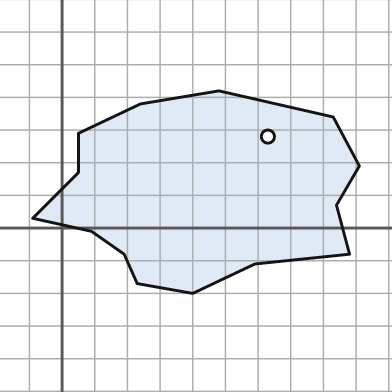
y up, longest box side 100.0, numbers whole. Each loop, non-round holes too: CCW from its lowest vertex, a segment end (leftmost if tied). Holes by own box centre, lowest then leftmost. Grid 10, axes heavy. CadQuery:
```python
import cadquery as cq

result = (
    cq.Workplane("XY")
    .moveTo(40.0, -20.0)
    .lineTo(59.0, -11.0)
    .lineTo(88.0, -8.0)
    .lineTo(84.0, 7.0)
    .lineTo(91.0, 19.0)
    .lineTo(83.0, 34.0)
    .lineTo(48.0, 42.0)
    .lineTo(24.0, 38.0)
    .lineTo(5.0, 29.0)
    .lineTo(5.0, 17.0)
    .lineTo(-9.0, 3.0)
    .lineTo(9.0, -1.0)
    .lineTo(19.0, -8.0)
    .lineTo(23.0, -17.0)
    .close()
    .moveTo(63.0, 28.0)
    .circle(2.0)
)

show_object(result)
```